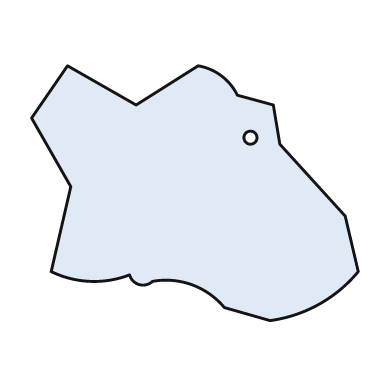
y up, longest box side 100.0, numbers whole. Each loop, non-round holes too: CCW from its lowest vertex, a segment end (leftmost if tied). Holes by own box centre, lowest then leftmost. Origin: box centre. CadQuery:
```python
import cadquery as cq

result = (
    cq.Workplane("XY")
    .moveTo(23.0, -39.0)
    .threePointArc((38.0, -34.0), (50.0, -24.0))
    .lineTo(46.0, -7.0)
    .lineTo(26.0, 15.0)
    .lineTo(24.0, 27.0)
    .lineTo(13.0, 30.0)
    .threePointArc((8.0, 36.0), (1.0, 39.0))
    .lineTo(-18.0, 27.0)
    .lineTo(-39.0, 39.0)
    .lineTo(-50.0, 23.0)
    .lineTo(-38.0, 2.0)
    .lineTo(-44.0, -24.0)
    .threePointArc((-32.0, -27.0), (-20.0, -25.0))
    .threePointArc((-17.0, -28.0), (-13.0, -27.0))
    .threePointArc((-1.0, -28.0), (9.0, -35.0))
    .close()
    .moveTo(17.0, 17.0)
    .circle(2.0)
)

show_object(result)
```